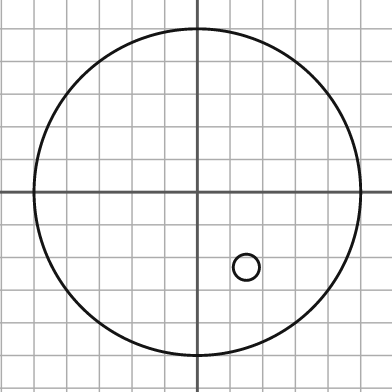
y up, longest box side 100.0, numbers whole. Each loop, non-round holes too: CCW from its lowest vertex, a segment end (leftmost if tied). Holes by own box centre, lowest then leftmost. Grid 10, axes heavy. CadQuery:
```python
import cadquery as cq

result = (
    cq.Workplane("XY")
    .moveTo(0.0, 0.0)
    .circle(50.0)
    .moveTo(15.0, -23.0)
    .circle(4.0)
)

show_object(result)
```